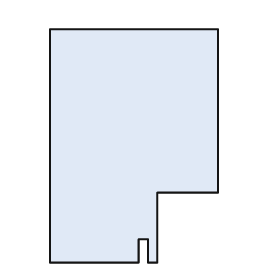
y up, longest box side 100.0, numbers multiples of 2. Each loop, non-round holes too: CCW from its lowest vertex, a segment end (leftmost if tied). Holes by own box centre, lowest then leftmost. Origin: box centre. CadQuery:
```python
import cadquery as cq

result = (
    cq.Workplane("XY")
    .moveTo(-36.0, -50.0)
    .lineTo(2.0, -50.0)
    .lineTo(2.0, -40.0)
    .lineTo(6.0, -40.0)
    .lineTo(6.0, -50.0)
    .lineTo(10.0, -50.0)
    .lineTo(10.0, -20.0)
    .lineTo(36.0, -20.0)
    .lineTo(36.0, 50.0)
    .lineTo(-36.0, 50.0)
    .close()
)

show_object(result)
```